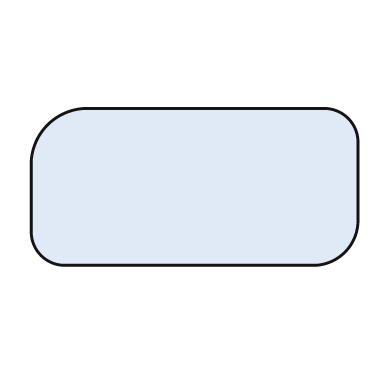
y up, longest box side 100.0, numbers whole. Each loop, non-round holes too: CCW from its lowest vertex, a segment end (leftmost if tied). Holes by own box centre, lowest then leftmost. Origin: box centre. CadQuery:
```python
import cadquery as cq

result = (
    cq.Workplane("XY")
    .moveTo(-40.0, -24.0)
    .lineTo(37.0, -24.0)
    .threePointArc((46.0, -20.0), (50.0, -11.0))
    .lineTo(50.0, 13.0)
    .threePointArc((47.0, 21.0), (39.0, 24.0))
    .lineTo(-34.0, 24.0)
    .threePointArc((-45.0, 19.0), (-50.0, 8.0))
    .lineTo(-50.0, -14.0)
    .threePointArc((-47.0, -21.0), (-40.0, -24.0))
    .close()
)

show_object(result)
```